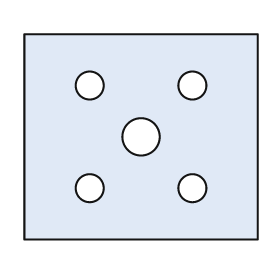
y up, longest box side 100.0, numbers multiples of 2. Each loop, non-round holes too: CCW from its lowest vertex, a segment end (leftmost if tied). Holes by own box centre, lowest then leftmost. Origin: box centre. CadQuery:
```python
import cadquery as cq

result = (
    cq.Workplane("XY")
    .moveTo(-50.0, -44.0)
    .lineTo(50.0, -44.0)
    .lineTo(50.0, 44.0)
    .lineTo(-50.0, 44.0)
    .close()
    .moveTo(-22.0, -22.0)
    .circle(6.0)
    .moveTo(22.0, -22.0)
    .circle(6.0)
    .moveTo(0.0, 0.0)
    .circle(8.0)
    .moveTo(-22.0, 22.0)
    .circle(6.0)
    .moveTo(22.0, 22.0)
    .circle(6.0)
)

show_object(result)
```